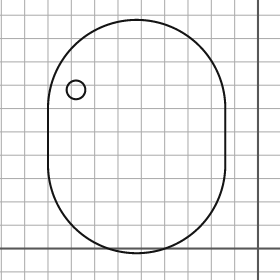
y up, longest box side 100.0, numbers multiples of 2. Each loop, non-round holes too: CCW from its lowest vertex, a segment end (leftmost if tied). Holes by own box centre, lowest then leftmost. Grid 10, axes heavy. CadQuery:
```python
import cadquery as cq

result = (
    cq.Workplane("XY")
    .moveTo(-90.0, 36.0)
    .threePointArc((-52.0, -2.0), (-14.0, 36.0))
    .lineTo(-14.0, 60.0)
    .threePointArc((-52.0, 98.0), (-90.0, 60.0))
    .close()
    .moveTo(-78.0, 68.0)
    .circle(4.0)
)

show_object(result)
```